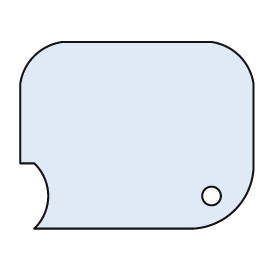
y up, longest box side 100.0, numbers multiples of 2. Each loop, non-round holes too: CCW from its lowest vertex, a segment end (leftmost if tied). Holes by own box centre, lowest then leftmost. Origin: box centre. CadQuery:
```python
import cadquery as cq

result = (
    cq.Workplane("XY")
    .moveTo(-44.0, -40.0)
    .lineTo(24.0, -40.0)
    .threePointArc((42.0, -32.0), (50.0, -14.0))
    .lineTo(50.0, 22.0)
    .threePointArc((44.0, 34.0), (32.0, 40.0))
    .lineTo(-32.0, 40.0)
    .threePointArc((-44.0, 34.0), (-50.0, 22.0))
    .lineTo(-50.0, -12.0)
    .lineTo(-44.0, -12.0)
    .threePointArc((-38.0, -26.0), (-44.0, -40.0))
    .close()
    .moveTo(32.0, -26.0)
    .circle(4.0)
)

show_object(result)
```